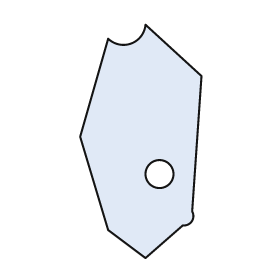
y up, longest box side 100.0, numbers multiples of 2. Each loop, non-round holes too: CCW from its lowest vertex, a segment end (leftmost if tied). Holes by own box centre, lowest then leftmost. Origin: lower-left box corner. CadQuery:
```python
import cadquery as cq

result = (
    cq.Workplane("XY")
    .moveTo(28.0, 0.0)
    .lineTo(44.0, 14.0)
    .threePointArc((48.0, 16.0), (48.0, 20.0))
    .lineTo(52.0, 78.0)
    .lineTo(28.0, 100.0)
    .threePointArc((22.0, 92.0), (12.0, 94.0))
    .lineTo(0.0, 52.0)
    .lineTo(12.0, 12.0)
    .close()
    .moveTo(34.0, 36.0)
    .circle(6.0)
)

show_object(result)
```